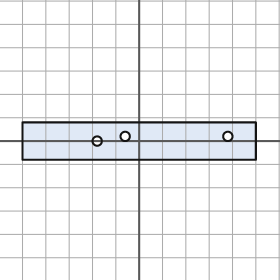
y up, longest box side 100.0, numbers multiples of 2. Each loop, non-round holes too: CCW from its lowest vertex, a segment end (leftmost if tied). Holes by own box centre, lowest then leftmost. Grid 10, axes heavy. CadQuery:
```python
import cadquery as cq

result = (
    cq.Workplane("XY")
    .moveTo(-50.0, -8.0)
    .lineTo(50.0, -8.0)
    .lineTo(50.0, 8.0)
    .lineTo(-50.0, 8.0)
    .close()
    .moveTo(-18.0, 0.0)
    .circle(2.0)
    .moveTo(-6.0, 2.0)
    .circle(2.0)
    .moveTo(38.0, 2.0)
    .circle(2.0)
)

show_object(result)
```